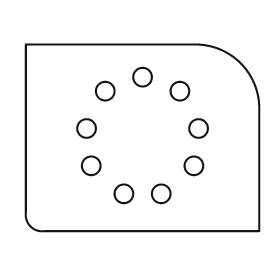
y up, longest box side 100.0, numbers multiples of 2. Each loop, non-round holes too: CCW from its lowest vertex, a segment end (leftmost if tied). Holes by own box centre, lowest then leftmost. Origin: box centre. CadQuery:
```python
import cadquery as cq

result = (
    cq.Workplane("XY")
    .moveTo(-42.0, -40.0)
    .lineTo(50.0, -40.0)
    .lineTo(50.0, 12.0)
    .threePointArc((42.0, 32.0), (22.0, 40.0))
    .lineTo(-50.0, 40.0)
    .lineTo(-50.0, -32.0)
    .threePointArc((-48.0, -38.0), (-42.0, -40.0))
    .close()
    .moveTo(-8.0, -24.0)
    .circle(4.0)
    .moveTo(8.0, -24.0)
    .circle(4.0)
    .moveTo(-22.0, -12.0)
    .circle(4.0)
    .moveTo(22.0, -12.0)
    .circle(4.0)
    .moveTo(-24.0, 4.0)
    .circle(4.0)
    .moveTo(24.0, 4.0)
    .circle(4.0)
    .moveTo(-16.0, 20.0)
    .circle(4.0)
    .moveTo(16.0, 20.0)
    .circle(4.0)
    .moveTo(0.0, 26.0)
    .circle(4.0)
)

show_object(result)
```